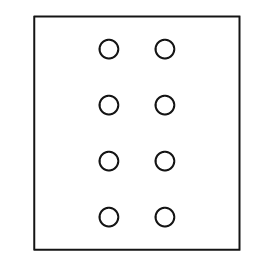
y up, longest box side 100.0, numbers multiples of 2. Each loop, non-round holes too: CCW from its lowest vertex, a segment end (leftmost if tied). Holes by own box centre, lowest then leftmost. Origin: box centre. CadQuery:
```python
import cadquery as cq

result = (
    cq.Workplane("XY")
    .moveTo(-44.0, -50.0)
    .lineTo(44.0, -50.0)
    .lineTo(44.0, 50.0)
    .lineTo(-44.0, 50.0)
    .close()
    .moveTo(-12.0, -36.0)
    .circle(4.0)
    .moveTo(12.0, -36.0)
    .circle(4.0)
    .moveTo(-12.0, -12.0)
    .circle(4.0)
    .moveTo(12.0, -12.0)
    .circle(4.0)
    .moveTo(-12.0, 12.0)
    .circle(4.0)
    .moveTo(12.0, 12.0)
    .circle(4.0)
    .moveTo(-12.0, 36.0)
    .circle(4.0)
    .moveTo(12.0, 36.0)
    .circle(4.0)
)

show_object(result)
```